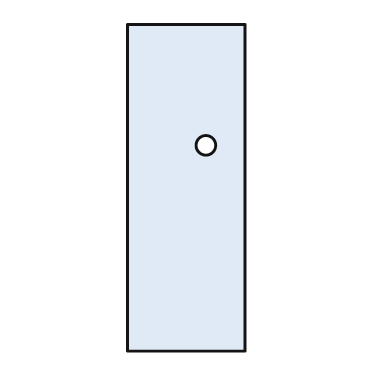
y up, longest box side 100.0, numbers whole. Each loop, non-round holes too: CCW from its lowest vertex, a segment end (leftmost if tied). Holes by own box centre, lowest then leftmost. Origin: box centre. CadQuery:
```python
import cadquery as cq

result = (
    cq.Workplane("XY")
    .moveTo(-18.0, -50.0)
    .lineTo(18.0, -50.0)
    .lineTo(18.0, 50.0)
    .lineTo(-18.0, 50.0)
    .close()
    .moveTo(6.0, 13.0)
    .circle(3.0)
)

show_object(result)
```